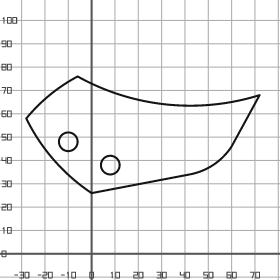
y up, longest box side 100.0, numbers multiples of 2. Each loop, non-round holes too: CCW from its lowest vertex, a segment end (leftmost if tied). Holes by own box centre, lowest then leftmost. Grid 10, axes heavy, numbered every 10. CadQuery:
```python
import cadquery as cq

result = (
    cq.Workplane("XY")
    .moveTo(0.0, 26.0)
    .lineTo(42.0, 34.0)
    .threePointArc((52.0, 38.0), (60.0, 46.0))
    .lineTo(72.0, 68.0)
    .threePointArc((32.0, 64.0), (-6.0, 76.0))
    .threePointArc((-18.0, 68.0), (-28.0, 58.0))
    .threePointArc((-16.0, 40.0), (0.0, 26.0))
    .close()
    .moveTo(8.0, 38.0)
    .circle(4.0)
    .moveTo(-10.0, 48.0)
    .circle(4.0)
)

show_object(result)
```